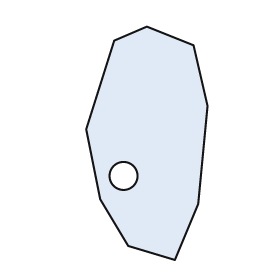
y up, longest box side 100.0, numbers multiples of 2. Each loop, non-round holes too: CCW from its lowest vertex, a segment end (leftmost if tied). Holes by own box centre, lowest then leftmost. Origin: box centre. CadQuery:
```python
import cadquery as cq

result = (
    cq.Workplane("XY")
    .moveTo(12.0, -50.0)
    .lineTo(22.0, -26.0)
    .lineTo(26.0, 16.0)
    .lineTo(20.0, 42.0)
    .lineTo(0.0, 50.0)
    .lineTo(-14.0, 44.0)
    .lineTo(-26.0, 6.0)
    .lineTo(-20.0, -24.0)
    .lineTo(-8.0, -44.0)
    .close()
    .moveTo(-10.0, -14.0)
    .circle(6.0)
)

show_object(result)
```